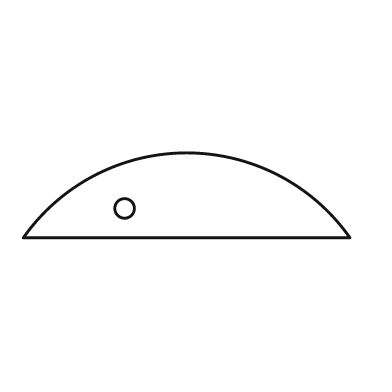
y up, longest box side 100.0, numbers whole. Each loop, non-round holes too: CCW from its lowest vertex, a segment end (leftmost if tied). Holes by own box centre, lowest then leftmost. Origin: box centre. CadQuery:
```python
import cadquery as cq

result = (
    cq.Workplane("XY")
    .moveTo(-50.0, -13.0)
    .lineTo(50.0, -13.0)
    .threePointArc((0.0, 13.0), (-50.0, -13.0))
    .close()
    .moveTo(-19.0, -4.0)
    .circle(3.0)
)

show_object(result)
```